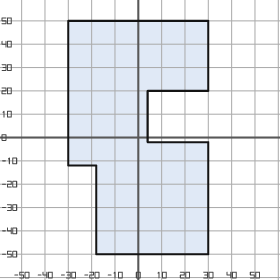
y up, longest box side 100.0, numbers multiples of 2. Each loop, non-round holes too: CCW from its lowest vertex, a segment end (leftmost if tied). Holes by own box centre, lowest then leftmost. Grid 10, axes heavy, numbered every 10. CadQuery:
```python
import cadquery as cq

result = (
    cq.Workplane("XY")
    .moveTo(-18.0, -50.0)
    .lineTo(30.0, -50.0)
    .lineTo(30.0, -2.0)
    .lineTo(4.0, -2.0)
    .lineTo(4.0, 20.0)
    .lineTo(30.0, 20.0)
    .lineTo(30.0, 50.0)
    .lineTo(-30.0, 50.0)
    .lineTo(-30.0, -12.0)
    .lineTo(-18.0, -12.0)
    .close()
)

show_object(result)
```